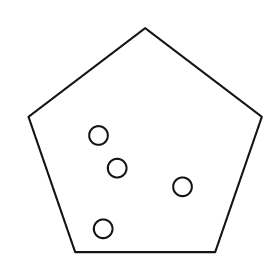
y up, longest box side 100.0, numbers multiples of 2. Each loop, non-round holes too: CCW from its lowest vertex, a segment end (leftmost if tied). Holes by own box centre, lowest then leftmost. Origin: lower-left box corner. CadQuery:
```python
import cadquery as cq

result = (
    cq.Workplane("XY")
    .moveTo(20.0, 0.0)
    .lineTo(80.0, 0.0)
    .lineTo(100.0, 58.0)
    .lineTo(50.0, 96.0)
    .lineTo(0.0, 58.0)
    .close()
    .moveTo(32.0, 10.0)
    .circle(4.0)
    .moveTo(66.0, 28.0)
    .circle(4.0)
    .moveTo(38.0, 36.0)
    .circle(4.0)
    .moveTo(30.0, 50.0)
    .circle(4.0)
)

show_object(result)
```